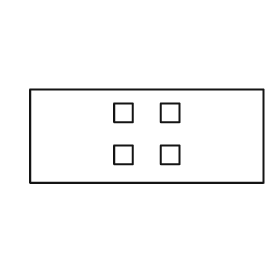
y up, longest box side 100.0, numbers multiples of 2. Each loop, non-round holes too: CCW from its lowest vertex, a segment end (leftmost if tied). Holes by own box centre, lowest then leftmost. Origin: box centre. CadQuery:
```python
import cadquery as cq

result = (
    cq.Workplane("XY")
    .moveTo(-50.0, -20.0)
    .lineTo(50.0, -20.0)
    .lineTo(50.0, 20.0)
    .lineTo(-50.0, 20.0)
    .close()
    .moveTo(-14.0, -12.0)
    .lineTo(-6.0, -12.0)
    .lineTo(-6.0, -4.0)
    .lineTo(-14.0, -4.0)
    .close()
    .moveTo(6.0, -12.0)
    .lineTo(14.0, -12.0)
    .lineTo(14.0, -4.0)
    .lineTo(6.0, -4.0)
    .close()
    .moveTo(-14.0, 6.0)
    .lineTo(-6.0, 6.0)
    .lineTo(-6.0, 14.0)
    .lineTo(-14.0, 14.0)
    .close()
    .moveTo(6.0, 6.0)
    .lineTo(14.0, 6.0)
    .lineTo(14.0, 14.0)
    .lineTo(6.0, 14.0)
    .close()
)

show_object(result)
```